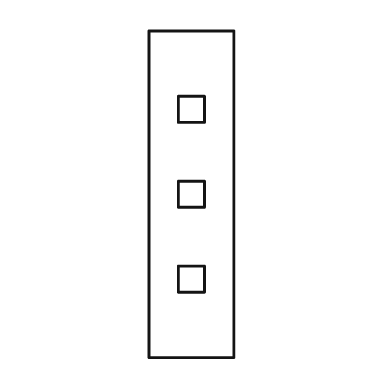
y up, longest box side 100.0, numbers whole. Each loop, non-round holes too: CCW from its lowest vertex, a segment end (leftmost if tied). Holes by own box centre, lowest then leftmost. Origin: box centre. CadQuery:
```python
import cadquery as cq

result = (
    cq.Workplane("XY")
    .moveTo(-13.0, -50.0)
    .lineTo(13.0, -50.0)
    .lineTo(13.0, 50.0)
    .lineTo(-13.0, 50.0)
    .close()
    .moveTo(-4.0, -30.0)
    .lineTo(4.0, -30.0)
    .lineTo(4.0, -22.0)
    .lineTo(-4.0, -22.0)
    .close()
    .moveTo(-4.0, -4.0)
    .lineTo(4.0, -4.0)
    .lineTo(4.0, 4.0)
    .lineTo(-4.0, 4.0)
    .close()
    .moveTo(-4.0, 22.0)
    .lineTo(4.0, 22.0)
    .lineTo(4.0, 30.0)
    .lineTo(-4.0, 30.0)
    .close()
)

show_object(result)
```